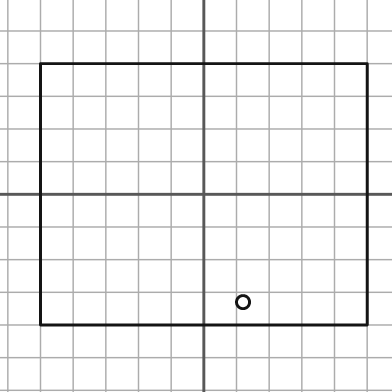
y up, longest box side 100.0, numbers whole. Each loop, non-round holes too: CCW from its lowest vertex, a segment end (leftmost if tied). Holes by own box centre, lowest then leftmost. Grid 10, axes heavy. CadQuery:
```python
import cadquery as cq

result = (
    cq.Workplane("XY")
    .moveTo(-50.0, -40.0)
    .lineTo(50.0, -40.0)
    .lineTo(50.0, 40.0)
    .lineTo(-50.0, 40.0)
    .close()
    .moveTo(12.0, -33.0)
    .circle(2.0)
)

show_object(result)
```